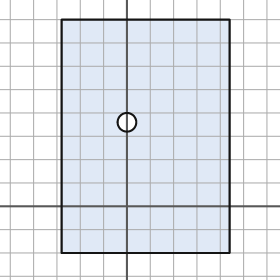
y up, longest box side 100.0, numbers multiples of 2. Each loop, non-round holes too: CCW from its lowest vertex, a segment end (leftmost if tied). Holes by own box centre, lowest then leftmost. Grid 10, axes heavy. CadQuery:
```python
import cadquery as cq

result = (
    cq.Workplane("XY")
    .moveTo(-28.0, -20.0)
    .lineTo(44.0, -20.0)
    .lineTo(44.0, 80.0)
    .lineTo(-28.0, 80.0)
    .close()
    .moveTo(0.0, 36.0)
    .circle(4.0)
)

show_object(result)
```